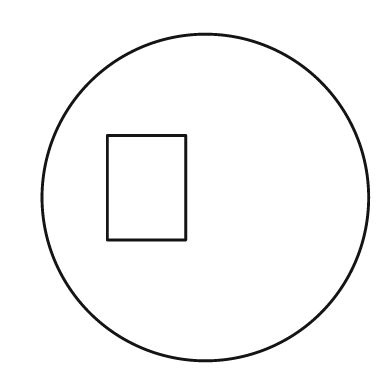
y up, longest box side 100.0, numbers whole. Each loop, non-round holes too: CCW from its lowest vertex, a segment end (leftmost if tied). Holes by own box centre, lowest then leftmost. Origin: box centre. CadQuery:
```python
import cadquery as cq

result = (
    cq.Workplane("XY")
    .moveTo(0.0, 0.0)
    .circle(50.0)
    .moveTo(-30.0, -13.0)
    .lineTo(-6.0, -13.0)
    .lineTo(-6.0, 19.0)
    .lineTo(-30.0, 19.0)
    .close()
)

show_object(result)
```